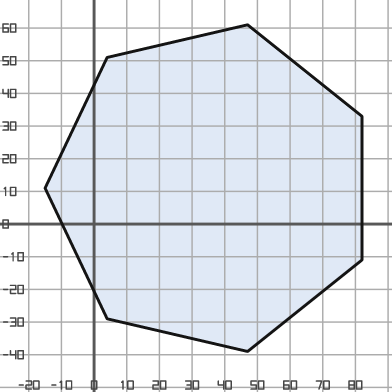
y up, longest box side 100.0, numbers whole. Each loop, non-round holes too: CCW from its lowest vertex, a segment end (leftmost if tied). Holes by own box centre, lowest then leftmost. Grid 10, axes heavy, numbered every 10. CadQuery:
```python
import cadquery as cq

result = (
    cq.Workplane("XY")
    .moveTo(47.0, -39.0)
    .lineTo(82.0, -11.0)
    .lineTo(82.0, 33.0)
    .lineTo(47.0, 61.0)
    .lineTo(4.0, 51.0)
    .lineTo(-15.0, 11.0)
    .lineTo(4.0, -29.0)
    .close()
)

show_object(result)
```